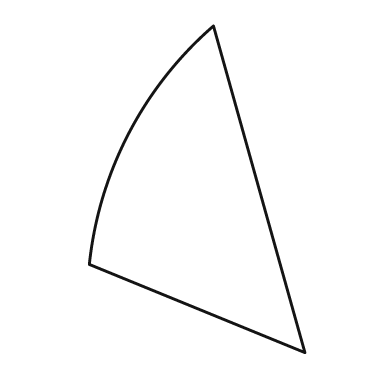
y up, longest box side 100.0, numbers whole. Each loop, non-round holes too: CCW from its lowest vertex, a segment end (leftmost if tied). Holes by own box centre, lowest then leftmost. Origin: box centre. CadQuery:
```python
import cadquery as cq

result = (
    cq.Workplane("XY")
    .moveTo(33.0, -50.0)
    .lineTo(5.0, 50.0)
    .threePointArc((-21.0, 17.0), (-33.0, -23.0))
    .close()
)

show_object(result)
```